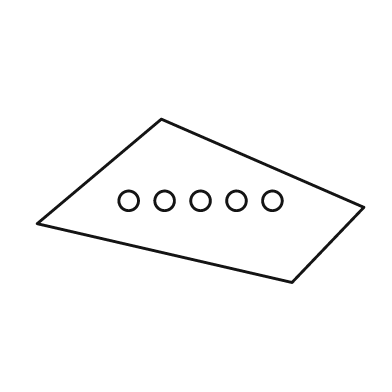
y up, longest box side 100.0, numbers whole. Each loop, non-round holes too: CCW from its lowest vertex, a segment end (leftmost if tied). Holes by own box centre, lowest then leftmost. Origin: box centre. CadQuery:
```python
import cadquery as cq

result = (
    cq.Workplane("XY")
    .moveTo(28.0, -25.0)
    .lineTo(50.0, -2.0)
    .lineTo(-12.0, 25.0)
    .lineTo(-50.0, -7.0)
    .close()
    .moveTo(-22.0, 0.0)
    .circle(3.0)
    .moveTo(-11.0, 0.0)
    .circle(3.0)
    .moveTo(0.0, 0.0)
    .circle(3.0)
    .moveTo(11.0, 0.0)
    .circle(3.0)
    .moveTo(22.0, 0.0)
    .circle(3.0)
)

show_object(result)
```